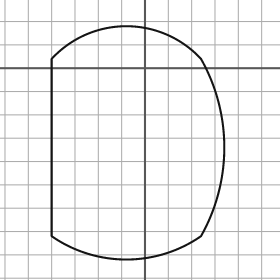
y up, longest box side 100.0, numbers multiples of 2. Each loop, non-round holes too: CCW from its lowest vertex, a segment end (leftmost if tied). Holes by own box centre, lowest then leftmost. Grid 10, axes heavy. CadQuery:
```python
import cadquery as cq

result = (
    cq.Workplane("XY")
    .moveTo(-40.0, -72.0)
    .threePointArc((-8.0, -82.0), (24.0, -72.0))
    .threePointArc((34.0, -34.0), (24.0, 4.0))
    .threePointArc((-8.0, 18.0), (-40.0, 4.0))
    .close()
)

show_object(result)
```